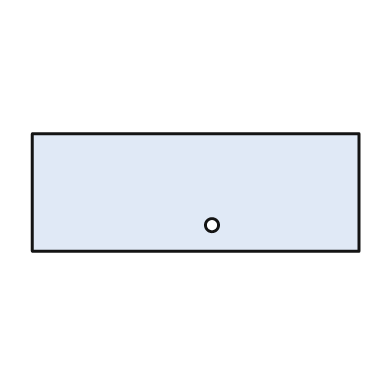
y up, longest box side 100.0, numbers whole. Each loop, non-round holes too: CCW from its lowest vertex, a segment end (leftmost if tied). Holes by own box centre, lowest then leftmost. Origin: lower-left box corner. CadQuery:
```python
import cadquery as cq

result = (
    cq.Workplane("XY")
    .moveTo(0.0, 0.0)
    .lineTo(100.0, 0.0)
    .lineTo(100.0, 36.0)
    .lineTo(0.0, 36.0)
    .close()
    .moveTo(55.0, 8.0)
    .circle(2.0)
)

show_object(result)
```